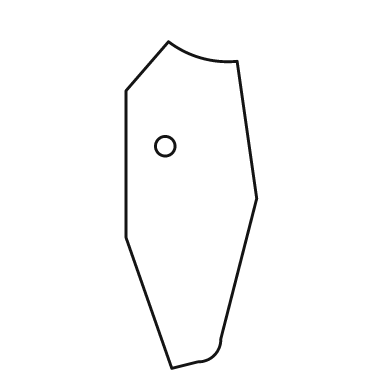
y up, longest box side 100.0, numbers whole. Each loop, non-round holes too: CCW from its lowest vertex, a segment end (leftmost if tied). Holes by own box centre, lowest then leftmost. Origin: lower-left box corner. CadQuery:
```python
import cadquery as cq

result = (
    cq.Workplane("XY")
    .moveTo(14.0, 0.0)
    .lineTo(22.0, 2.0)
    .threePointArc((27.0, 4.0), (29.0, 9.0))
    .lineTo(40.0, 52.0)
    .lineTo(34.0, 94.0)
    .threePointArc((23.0, 95.0), (13.0, 100.0))
    .lineTo(0.0, 85.0)
    .lineTo(0.0, 40.0)
    .close()
    .moveTo(12.0, 68.0)
    .circle(3.0)
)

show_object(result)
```